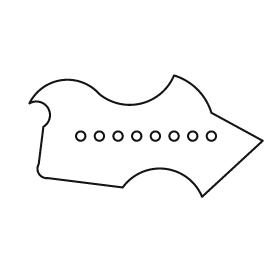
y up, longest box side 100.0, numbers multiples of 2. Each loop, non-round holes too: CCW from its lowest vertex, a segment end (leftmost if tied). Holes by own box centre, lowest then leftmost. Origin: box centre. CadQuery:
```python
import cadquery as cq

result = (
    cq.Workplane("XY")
    .moveTo(24.0, -26.0)
    .lineTo(50.0, -2.0)
    .lineTo(28.0, 10.0)
    .threePointArc((22.0, 20.0), (12.0, 26.0))
    .threePointArc((-2.0, 14.0), (-20.0, 18.0))
    .threePointArc((-36.0, 24.0), (-50.0, 14.0))
    .threePointArc((-42.0, 12.0), (-44.0, 4.0))
    .lineTo(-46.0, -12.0)
    .threePointArc((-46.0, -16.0), (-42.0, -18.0))
    .lineTo(-10.0, -22.0)
    .threePointArc((8.0, -14.0), (24.0, -26.0))
    .close()
    .moveTo(-28.0, 0.0)
    .circle(2.0)
    .moveTo(-20.0, 0.0)
    .circle(2.0)
    .moveTo(-12.0, 0.0)
    .circle(2.0)
    .moveTo(-4.0, 0.0)
    .circle(2.0)
    .moveTo(4.0, 0.0)
    .circle(2.0)
    .moveTo(12.0, 0.0)
    .circle(2.0)
    .moveTo(20.0, 0.0)
    .circle(2.0)
    .moveTo(28.0, 0.0)
    .circle(2.0)
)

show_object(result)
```